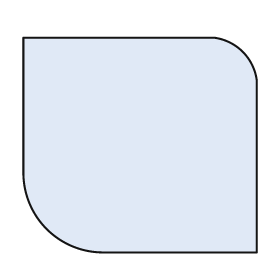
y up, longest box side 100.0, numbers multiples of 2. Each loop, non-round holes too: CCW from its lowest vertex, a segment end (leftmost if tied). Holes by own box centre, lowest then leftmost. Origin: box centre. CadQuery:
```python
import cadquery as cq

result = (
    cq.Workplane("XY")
    .moveTo(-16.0, -46.0)
    .lineTo(50.0, -46.0)
    .lineTo(50.0, 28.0)
    .threePointArc((44.0, 40.0), (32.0, 46.0))
    .lineTo(-50.0, 46.0)
    .lineTo(-50.0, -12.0)
    .threePointArc((-40.0, -36.0), (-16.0, -46.0))
    .close()
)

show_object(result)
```